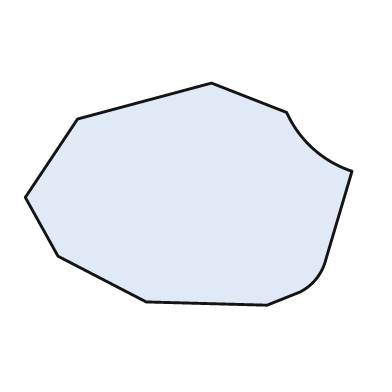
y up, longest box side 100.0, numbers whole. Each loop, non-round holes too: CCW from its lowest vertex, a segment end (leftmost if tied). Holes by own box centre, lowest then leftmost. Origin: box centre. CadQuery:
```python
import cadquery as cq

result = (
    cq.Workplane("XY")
    .moveTo(24.0, -34.0)
    .lineTo(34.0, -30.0)
    .threePointArc((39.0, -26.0), (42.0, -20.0))
    .lineTo(50.0, 7.0)
    .threePointArc((38.0, 14.0), (30.0, 25.0))
    .lineTo(7.0, 34.0)
    .lineTo(-34.0, 23.0)
    .lineTo(-50.0, -1.0)
    .lineTo(-40.0, -19.0)
    .lineTo(-13.0, -33.0)
    .close()
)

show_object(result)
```